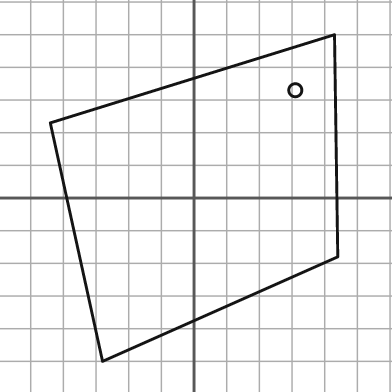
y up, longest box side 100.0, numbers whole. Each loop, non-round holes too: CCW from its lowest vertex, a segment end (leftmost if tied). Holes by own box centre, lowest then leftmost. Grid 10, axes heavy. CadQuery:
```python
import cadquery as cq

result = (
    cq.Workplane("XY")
    .moveTo(-28.0, -50.0)
    .lineTo(44.0, -18.0)
    .lineTo(43.0, 50.0)
    .lineTo(-44.0, 23.0)
    .close()
    .moveTo(31.0, 33.0)
    .circle(2.0)
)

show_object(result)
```